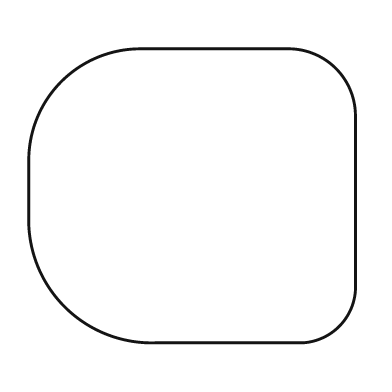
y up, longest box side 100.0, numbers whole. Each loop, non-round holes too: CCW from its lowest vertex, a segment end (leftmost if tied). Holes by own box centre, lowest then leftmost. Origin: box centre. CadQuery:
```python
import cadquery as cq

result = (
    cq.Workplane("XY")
    .moveTo(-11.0, -45.0)
    .lineTo(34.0, -45.0)
    .threePointArc((45.0, -40.0), (50.0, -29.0))
    .lineTo(50.0, 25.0)
    .threePointArc((44.0, 39.0), (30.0, 45.0))
    .lineTo(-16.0, 45.0)
    .threePointArc((-40.0, 35.0), (-50.0, 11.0))
    .lineTo(-50.0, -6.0)
    .threePointArc((-39.0, -34.0), (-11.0, -45.0))
    .close()
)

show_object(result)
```